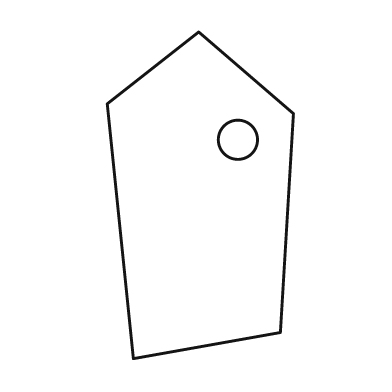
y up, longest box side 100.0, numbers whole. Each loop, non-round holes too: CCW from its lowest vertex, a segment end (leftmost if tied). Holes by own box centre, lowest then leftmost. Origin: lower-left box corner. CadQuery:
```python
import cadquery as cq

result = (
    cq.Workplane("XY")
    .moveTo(8.0, 0.0)
    .lineTo(53.0, 8.0)
    .lineTo(57.0, 75.0)
    .lineTo(28.0, 100.0)
    .lineTo(0.0, 78.0)
    .close()
    .moveTo(40.0, 67.0)
    .circle(6.0)
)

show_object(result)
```